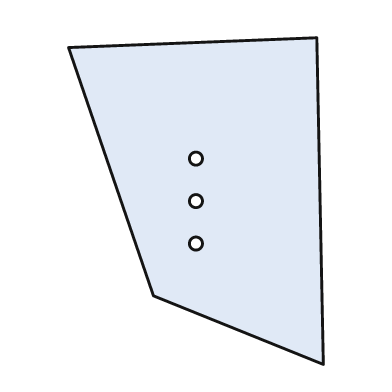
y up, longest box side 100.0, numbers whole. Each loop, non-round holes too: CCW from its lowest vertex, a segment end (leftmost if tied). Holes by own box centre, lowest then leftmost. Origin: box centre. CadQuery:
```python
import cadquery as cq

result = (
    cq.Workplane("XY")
    .moveTo(39.0, -50.0)
    .lineTo(37.0, 50.0)
    .lineTo(-39.0, 47.0)
    .lineTo(-13.0, -29.0)
    .close()
    .moveTo(0.0, -13.0)
    .circle(2.0)
    .moveTo(0.0, 0.0)
    .circle(2.0)
    .moveTo(0.0, 13.0)
    .circle(2.0)
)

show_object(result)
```